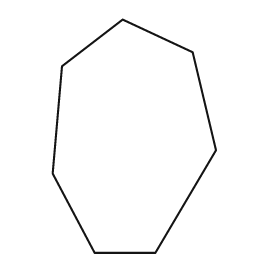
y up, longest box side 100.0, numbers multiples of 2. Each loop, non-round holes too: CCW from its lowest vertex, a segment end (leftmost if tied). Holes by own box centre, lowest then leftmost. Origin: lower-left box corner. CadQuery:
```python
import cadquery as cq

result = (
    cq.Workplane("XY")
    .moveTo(18.0, 0.0)
    .lineTo(44.0, 0.0)
    .lineTo(70.0, 44.0)
    .lineTo(60.0, 86.0)
    .lineTo(30.0, 100.0)
    .lineTo(4.0, 80.0)
    .lineTo(0.0, 34.0)
    .close()
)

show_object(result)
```